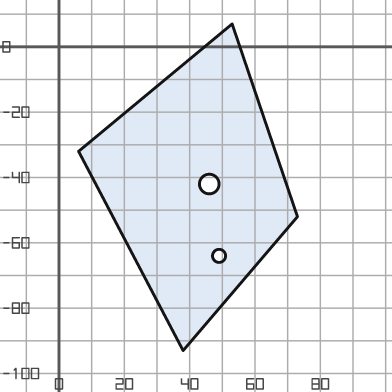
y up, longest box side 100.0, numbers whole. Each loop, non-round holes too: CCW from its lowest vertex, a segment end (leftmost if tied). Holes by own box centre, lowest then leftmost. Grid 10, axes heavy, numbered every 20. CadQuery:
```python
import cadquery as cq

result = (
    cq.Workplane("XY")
    .moveTo(38.0, -93.0)
    .lineTo(73.0, -52.0)
    .lineTo(53.0, 7.0)
    .lineTo(6.0, -32.0)
    .close()
    .moveTo(49.0, -64.0)
    .circle(2.0)
    .moveTo(46.0, -42.0)
    .circle(3.0)
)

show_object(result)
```